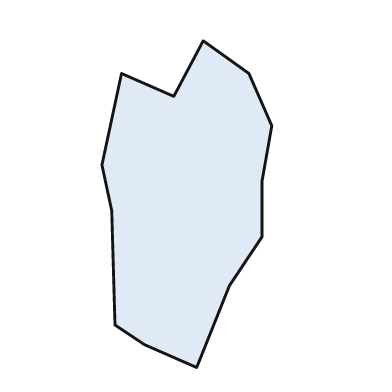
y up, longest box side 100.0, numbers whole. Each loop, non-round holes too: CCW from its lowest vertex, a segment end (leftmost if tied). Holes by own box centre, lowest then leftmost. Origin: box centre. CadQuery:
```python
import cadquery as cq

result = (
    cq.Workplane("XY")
    .moveTo(3.0, -50.0)
    .lineTo(13.0, -25.0)
    .lineTo(23.0, -10.0)
    .lineTo(23.0, 7.0)
    .lineTo(26.0, 24.0)
    .lineTo(19.0, 40.0)
    .lineTo(5.0, 50.0)
    .lineTo(-4.0, 33.0)
    .lineTo(-20.0, 40.0)
    .lineTo(-26.0, 12.0)
    .lineTo(-23.0, -2.0)
    .lineTo(-22.0, -37.0)
    .lineTo(-13.0, -43.0)
    .close()
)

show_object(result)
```